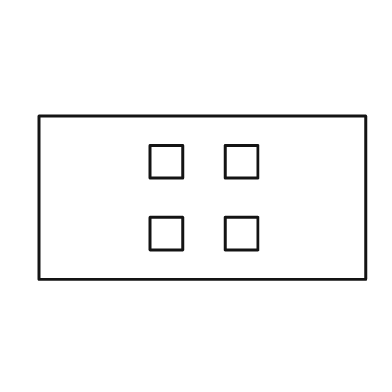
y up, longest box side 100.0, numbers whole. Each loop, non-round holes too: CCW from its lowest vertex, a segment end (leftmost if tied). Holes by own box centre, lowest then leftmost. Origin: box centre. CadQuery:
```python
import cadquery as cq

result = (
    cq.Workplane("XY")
    .moveTo(-50.0, -25.0)
    .lineTo(50.0, -25.0)
    .lineTo(50.0, 25.0)
    .lineTo(-50.0, 25.0)
    .close()
    .moveTo(-16.0, -16.0)
    .lineTo(-6.0, -16.0)
    .lineTo(-6.0, -6.0)
    .lineTo(-16.0, -6.0)
    .close()
    .moveTo(7.0, -16.0)
    .lineTo(17.0, -16.0)
    .lineTo(17.0, -6.0)
    .lineTo(7.0, -6.0)
    .close()
    .moveTo(-16.0, 6.0)
    .lineTo(-6.0, 6.0)
    .lineTo(-6.0, 16.0)
    .lineTo(-16.0, 16.0)
    .close()
    .moveTo(7.0, 6.0)
    .lineTo(17.0, 6.0)
    .lineTo(17.0, 16.0)
    .lineTo(7.0, 16.0)
    .close()
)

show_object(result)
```